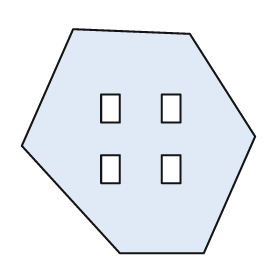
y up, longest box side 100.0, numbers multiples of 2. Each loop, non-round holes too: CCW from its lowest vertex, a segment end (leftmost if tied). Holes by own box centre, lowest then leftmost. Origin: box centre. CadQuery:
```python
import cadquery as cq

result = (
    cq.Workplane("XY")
    .moveTo(-8.0, -48.0)
    .lineTo(28.0, -48.0)
    .lineTo(50.0, 2.0)
    .lineTo(22.0, 46.0)
    .lineTo(-28.0, 48.0)
    .lineTo(-50.0, -2.0)
    .close()
    .moveTo(-16.0, -18.0)
    .lineTo(-8.0, -18.0)
    .lineTo(-8.0, -6.0)
    .lineTo(-16.0, -6.0)
    .close()
    .moveTo(10.0, -18.0)
    .lineTo(18.0, -18.0)
    .lineTo(18.0, -6.0)
    .lineTo(10.0, -6.0)
    .close()
    .moveTo(-16.0, 8.0)
    .lineTo(-8.0, 8.0)
    .lineTo(-8.0, 20.0)
    .lineTo(-16.0, 20.0)
    .close()
    .moveTo(10.0, 8.0)
    .lineTo(18.0, 8.0)
    .lineTo(18.0, 20.0)
    .lineTo(10.0, 20.0)
    .close()
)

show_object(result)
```